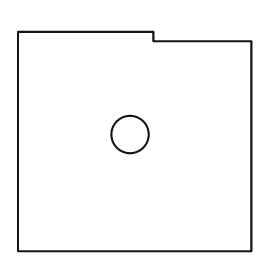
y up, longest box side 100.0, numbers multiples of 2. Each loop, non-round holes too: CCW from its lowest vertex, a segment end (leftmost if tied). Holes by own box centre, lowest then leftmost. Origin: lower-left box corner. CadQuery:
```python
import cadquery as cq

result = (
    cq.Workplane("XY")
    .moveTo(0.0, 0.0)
    .lineTo(100.0, 0.0)
    .lineTo(100.0, 90.0)
    .lineTo(58.0, 90.0)
    .lineTo(58.0, 94.0)
    .lineTo(0.0, 94.0)
    .close()
    .moveTo(48.0, 50.0)
    .circle(8.0)
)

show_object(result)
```